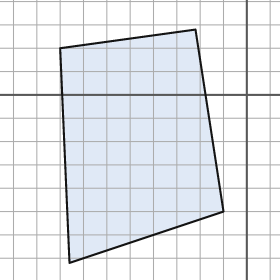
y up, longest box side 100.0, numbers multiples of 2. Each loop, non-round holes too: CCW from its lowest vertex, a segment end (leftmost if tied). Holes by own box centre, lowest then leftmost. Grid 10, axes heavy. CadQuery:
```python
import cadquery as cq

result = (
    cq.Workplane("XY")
    .moveTo(-76.0, -72.0)
    .lineTo(-10.0, -50.0)
    .lineTo(-22.0, 28.0)
    .lineTo(-80.0, 20.0)
    .close()
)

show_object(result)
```